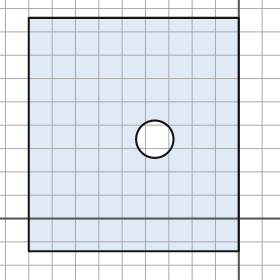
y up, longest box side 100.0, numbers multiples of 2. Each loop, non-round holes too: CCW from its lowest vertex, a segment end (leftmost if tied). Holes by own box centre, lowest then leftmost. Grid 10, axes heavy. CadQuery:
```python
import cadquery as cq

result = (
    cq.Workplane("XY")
    .moveTo(-90.0, -14.0)
    .lineTo(0.0, -14.0)
    .lineTo(0.0, 86.0)
    .lineTo(-90.0, 86.0)
    .close()
    .moveTo(-36.0, 34.0)
    .circle(8.0)
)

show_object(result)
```